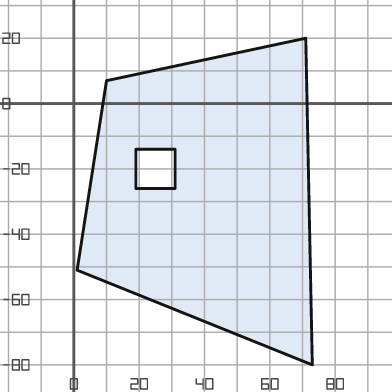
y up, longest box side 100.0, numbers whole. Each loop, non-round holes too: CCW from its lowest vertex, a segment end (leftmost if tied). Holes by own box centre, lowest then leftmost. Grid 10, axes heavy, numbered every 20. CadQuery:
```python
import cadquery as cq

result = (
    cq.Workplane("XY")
    .moveTo(73.0, -80.0)
    .lineTo(71.0, 20.0)
    .lineTo(10.0, 7.0)
    .lineTo(1.0, -51.0)
    .close()
    .moveTo(19.0, -26.0)
    .lineTo(31.0, -26.0)
    .lineTo(31.0, -14.0)
    .lineTo(19.0, -14.0)
    .close()
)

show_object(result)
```